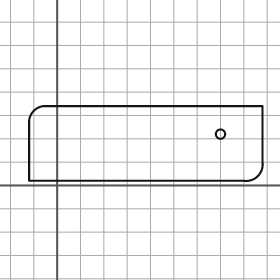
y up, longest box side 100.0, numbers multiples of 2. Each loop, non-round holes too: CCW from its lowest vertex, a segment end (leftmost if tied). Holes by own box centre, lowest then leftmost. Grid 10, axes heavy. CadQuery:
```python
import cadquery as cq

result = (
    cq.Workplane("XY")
    .moveTo(-12.0, 2.0)
    .lineTo(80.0, 2.0)
    .threePointArc((86.0, 4.0), (88.0, 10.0))
    .lineTo(88.0, 34.0)
    .lineTo(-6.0, 34.0)
    .threePointArc((-10.0, 32.0), (-12.0, 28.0))
    .close()
    .moveTo(70.0, 22.0)
    .circle(2.0)
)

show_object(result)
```